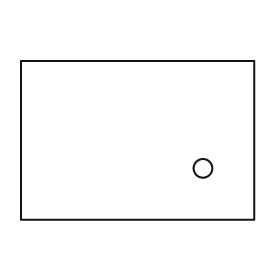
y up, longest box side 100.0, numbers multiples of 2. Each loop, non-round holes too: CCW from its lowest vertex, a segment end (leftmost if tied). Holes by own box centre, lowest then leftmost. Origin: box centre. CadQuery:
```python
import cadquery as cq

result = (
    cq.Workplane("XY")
    .moveTo(-50.0, -34.0)
    .lineTo(50.0, -34.0)
    .lineTo(50.0, 34.0)
    .lineTo(-50.0, 34.0)
    .close()
    .moveTo(28.0, -12.0)
    .circle(4.0)
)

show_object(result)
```